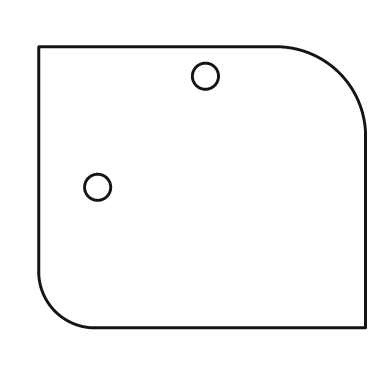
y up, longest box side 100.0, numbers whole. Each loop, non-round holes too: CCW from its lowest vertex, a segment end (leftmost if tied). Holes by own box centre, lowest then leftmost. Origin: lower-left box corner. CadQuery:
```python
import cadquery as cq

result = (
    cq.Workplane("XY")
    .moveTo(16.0, 0.0)
    .lineTo(100.0, 0.0)
    .lineTo(100.0, 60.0)
    .threePointArc((92.0, 78.0), (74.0, 86.0))
    .lineTo(0.0, 86.0)
    .lineTo(0.0, 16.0)
    .threePointArc((5.0, 5.0), (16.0, 0.0))
    .close()
    .moveTo(18.0, 43.0)
    .circle(4.0)
    .moveTo(51.0, 77.0)
    .circle(4.0)
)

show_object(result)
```